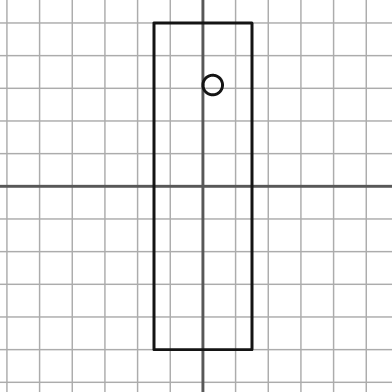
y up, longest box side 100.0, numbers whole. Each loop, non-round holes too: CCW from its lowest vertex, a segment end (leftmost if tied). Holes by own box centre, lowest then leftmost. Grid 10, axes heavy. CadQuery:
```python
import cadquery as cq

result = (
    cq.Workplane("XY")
    .moveTo(-15.0, -50.0)
    .lineTo(15.0, -50.0)
    .lineTo(15.0, 50.0)
    .lineTo(-15.0, 50.0)
    .close()
    .moveTo(3.0, 31.0)
    .circle(3.0)
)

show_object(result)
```